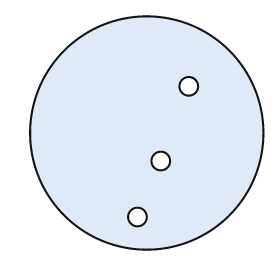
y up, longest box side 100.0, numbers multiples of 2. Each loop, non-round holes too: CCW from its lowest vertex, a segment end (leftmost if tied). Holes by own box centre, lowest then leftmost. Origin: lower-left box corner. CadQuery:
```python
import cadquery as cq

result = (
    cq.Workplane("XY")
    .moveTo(50.0, 50.0)
    .circle(50.0)
    .moveTo(46.0, 14.0)
    .circle(4.0)
    .moveTo(56.0, 38.0)
    .circle(4.0)
    .moveTo(68.0, 70.0)
    .circle(4.0)
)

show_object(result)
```